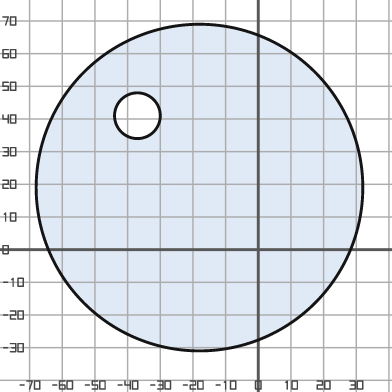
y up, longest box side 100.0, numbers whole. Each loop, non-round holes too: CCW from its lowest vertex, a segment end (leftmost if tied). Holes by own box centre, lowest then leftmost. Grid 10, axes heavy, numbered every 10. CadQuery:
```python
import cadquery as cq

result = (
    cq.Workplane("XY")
    .moveTo(-18.0, 19.0)
    .circle(50.0)
    .moveTo(-37.0, 41.0)
    .circle(7.0)
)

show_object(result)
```